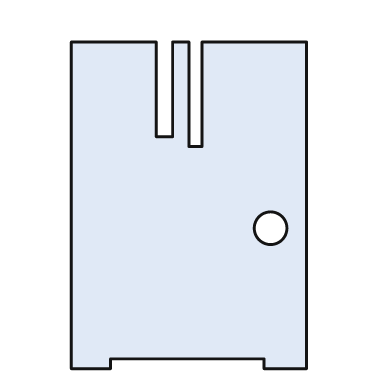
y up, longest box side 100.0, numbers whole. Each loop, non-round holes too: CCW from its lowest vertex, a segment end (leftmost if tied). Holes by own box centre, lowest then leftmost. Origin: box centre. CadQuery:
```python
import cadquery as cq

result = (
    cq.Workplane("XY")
    .moveTo(-36.0, -50.0)
    .lineTo(-24.0, -50.0)
    .lineTo(-24.0, -47.0)
    .lineTo(23.0, -47.0)
    .lineTo(23.0, -50.0)
    .lineTo(36.0, -50.0)
    .lineTo(36.0, 50.0)
    .lineTo(4.0, 50.0)
    .lineTo(4.0, 18.0)
    .lineTo(0.0, 18.0)
    .lineTo(0.0, 50.0)
    .lineTo(-5.0, 50.0)
    .lineTo(-5.0, 21.0)
    .lineTo(-10.0, 21.0)
    .lineTo(-10.0, 50.0)
    .lineTo(-36.0, 50.0)
    .close()
    .moveTo(25.0, -7.0)
    .circle(5.0)
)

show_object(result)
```